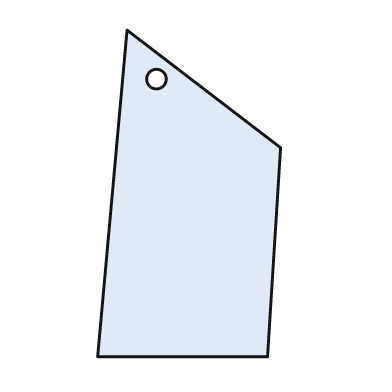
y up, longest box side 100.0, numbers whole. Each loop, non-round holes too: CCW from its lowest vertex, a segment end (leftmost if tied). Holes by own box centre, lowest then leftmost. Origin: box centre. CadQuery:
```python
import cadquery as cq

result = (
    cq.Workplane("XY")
    .moveTo(-28.0, -50.0)
    .lineTo(24.0, -50.0)
    .lineTo(28.0, 14.0)
    .lineTo(-19.0, 50.0)
    .close()
    .moveTo(-10.0, 35.0)
    .circle(3.0)
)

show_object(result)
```